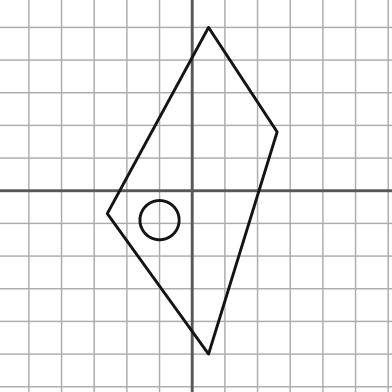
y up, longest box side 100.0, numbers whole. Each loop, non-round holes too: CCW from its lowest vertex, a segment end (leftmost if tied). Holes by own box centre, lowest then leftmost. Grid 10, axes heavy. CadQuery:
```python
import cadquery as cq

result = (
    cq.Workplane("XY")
    .moveTo(5.0, -50.0)
    .lineTo(26.0, 18.0)
    .lineTo(5.0, 50.0)
    .lineTo(-26.0, -7.0)
    .close()
    .moveTo(-10.0, -9.0)
    .circle(6.0)
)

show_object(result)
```